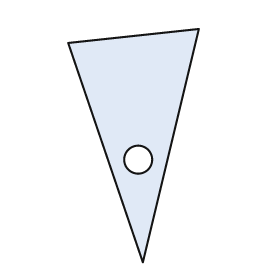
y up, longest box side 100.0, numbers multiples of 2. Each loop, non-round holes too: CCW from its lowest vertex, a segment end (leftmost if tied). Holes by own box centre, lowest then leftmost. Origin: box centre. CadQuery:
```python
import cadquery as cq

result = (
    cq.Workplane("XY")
    .moveTo(4.0, -50.0)
    .lineTo(28.0, 50.0)
    .lineTo(-28.0, 44.0)
    .close()
    .moveTo(2.0, -6.0)
    .circle(6.0)
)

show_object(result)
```